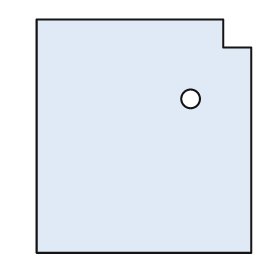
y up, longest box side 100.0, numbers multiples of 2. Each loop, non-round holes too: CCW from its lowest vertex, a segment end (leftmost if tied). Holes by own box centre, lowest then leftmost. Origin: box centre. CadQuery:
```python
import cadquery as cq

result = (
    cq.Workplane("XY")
    .moveTo(-46.0, -50.0)
    .lineTo(46.0, -50.0)
    .lineTo(46.0, 38.0)
    .lineTo(34.0, 38.0)
    .lineTo(34.0, 50.0)
    .lineTo(-46.0, 50.0)
    .close()
    .moveTo(20.0, 16.0)
    .circle(4.0)
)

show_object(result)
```